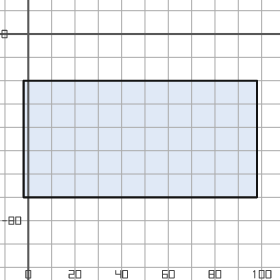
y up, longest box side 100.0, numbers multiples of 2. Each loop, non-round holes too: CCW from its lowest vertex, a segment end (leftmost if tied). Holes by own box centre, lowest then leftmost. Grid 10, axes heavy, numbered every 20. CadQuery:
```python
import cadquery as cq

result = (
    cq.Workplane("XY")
    .moveTo(-2.0, -70.0)
    .lineTo(98.0, -70.0)
    .lineTo(98.0, -20.0)
    .lineTo(-2.0, -20.0)
    .close()
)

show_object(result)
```